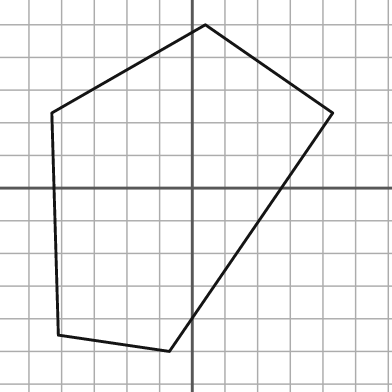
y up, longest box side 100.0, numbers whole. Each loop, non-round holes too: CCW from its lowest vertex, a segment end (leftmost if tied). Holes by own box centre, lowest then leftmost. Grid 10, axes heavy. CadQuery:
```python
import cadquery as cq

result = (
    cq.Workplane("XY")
    .moveTo(-7.0, -50.0)
    .lineTo(43.0, 23.0)
    .lineTo(4.0, 50.0)
    .lineTo(-43.0, 23.0)
    .lineTo(-41.0, -45.0)
    .close()
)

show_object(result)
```